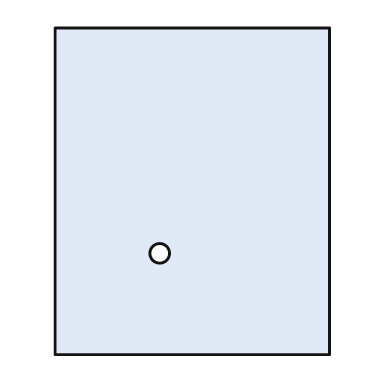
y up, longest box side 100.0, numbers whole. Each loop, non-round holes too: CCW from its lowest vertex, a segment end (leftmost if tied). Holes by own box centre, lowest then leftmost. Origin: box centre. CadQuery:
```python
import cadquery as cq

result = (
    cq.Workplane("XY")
    .moveTo(-42.0, -50.0)
    .lineTo(42.0, -50.0)
    .lineTo(42.0, 50.0)
    .lineTo(-42.0, 50.0)
    .close()
    .moveTo(-10.0, -19.0)
    .circle(3.0)
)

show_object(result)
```